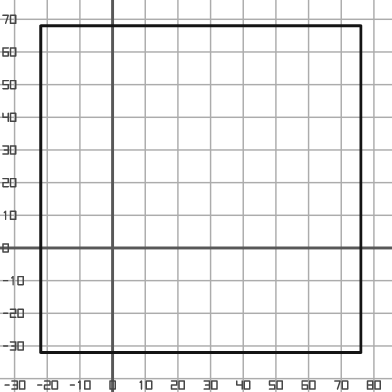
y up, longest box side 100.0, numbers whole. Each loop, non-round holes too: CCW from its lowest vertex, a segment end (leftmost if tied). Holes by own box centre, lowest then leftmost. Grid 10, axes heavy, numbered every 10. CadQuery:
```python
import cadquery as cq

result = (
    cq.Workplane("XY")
    .moveTo(-22.0, -32.0)
    .lineTo(76.0, -32.0)
    .lineTo(76.0, 68.0)
    .lineTo(-22.0, 68.0)
    .close()
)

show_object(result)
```